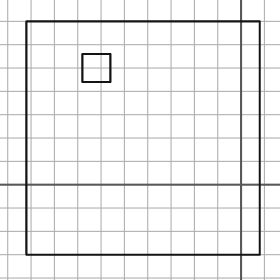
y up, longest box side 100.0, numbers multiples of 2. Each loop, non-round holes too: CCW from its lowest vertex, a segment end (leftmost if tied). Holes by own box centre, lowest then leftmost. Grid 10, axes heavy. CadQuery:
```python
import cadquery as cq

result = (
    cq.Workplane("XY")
    .moveTo(-92.0, -30.0)
    .lineTo(8.0, -30.0)
    .lineTo(8.0, 70.0)
    .lineTo(-92.0, 70.0)
    .close()
    .moveTo(-68.0, 44.0)
    .lineTo(-56.0, 44.0)
    .lineTo(-56.0, 56.0)
    .lineTo(-68.0, 56.0)
    .close()
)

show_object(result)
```